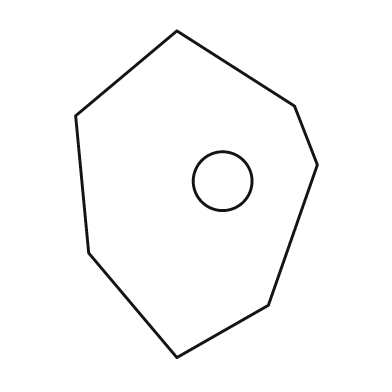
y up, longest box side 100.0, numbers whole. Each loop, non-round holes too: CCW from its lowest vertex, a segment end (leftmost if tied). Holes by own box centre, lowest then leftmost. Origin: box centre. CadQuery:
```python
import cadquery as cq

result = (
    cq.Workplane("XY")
    .moveTo(-6.0, -50.0)
    .lineTo(22.0, -34.0)
    .lineTo(37.0, 9.0)
    .lineTo(30.0, 27.0)
    .lineTo(-6.0, 50.0)
    .lineTo(-37.0, 24.0)
    .lineTo(-33.0, -18.0)
    .close()
    .moveTo(8.0, 4.0)
    .circle(9.0)
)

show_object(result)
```